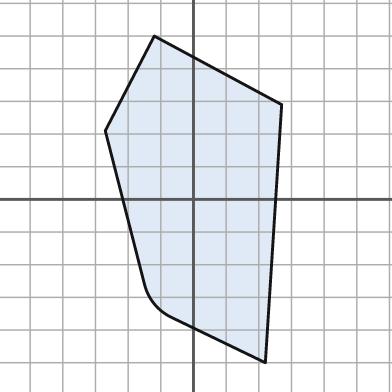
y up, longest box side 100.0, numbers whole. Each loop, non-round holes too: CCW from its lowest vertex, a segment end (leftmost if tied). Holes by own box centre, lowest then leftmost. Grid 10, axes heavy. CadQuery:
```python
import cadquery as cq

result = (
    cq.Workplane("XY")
    .moveTo(22.0, -50.0)
    .lineTo(27.0, 29.0)
    .lineTo(-12.0, 50.0)
    .lineTo(-27.0, 21.0)
    .lineTo(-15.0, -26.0)
    .threePointArc((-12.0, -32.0), (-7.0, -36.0))
    .close()
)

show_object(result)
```